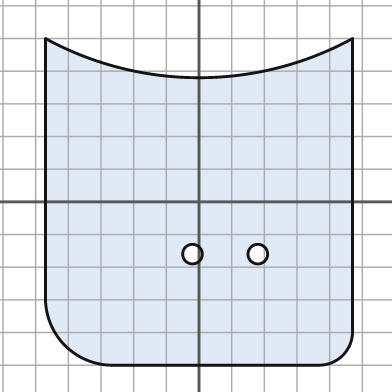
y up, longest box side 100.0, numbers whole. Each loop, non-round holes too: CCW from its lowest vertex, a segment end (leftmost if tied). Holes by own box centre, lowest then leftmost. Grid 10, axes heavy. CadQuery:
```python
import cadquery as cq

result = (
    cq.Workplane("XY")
    .moveTo(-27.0, -50.0)
    .lineTo(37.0, -50.0)
    .threePointArc((44.0, -47.0), (47.0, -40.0))
    .lineTo(47.0, 50.0)
    .threePointArc((0.0, 38.0), (-47.0, 50.0))
    .lineTo(-47.0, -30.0)
    .threePointArc((-41.0, -44.0), (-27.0, -50.0))
    .close()
    .moveTo(-2.0, -16.0)
    .circle(3.0)
    .moveTo(18.0, -16.0)
    .circle(3.0)
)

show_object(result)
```